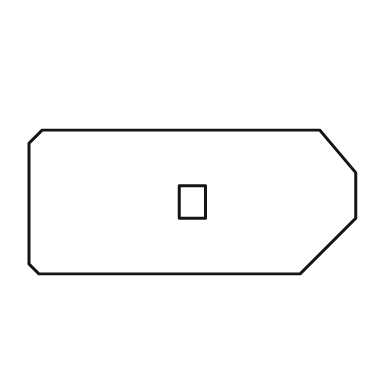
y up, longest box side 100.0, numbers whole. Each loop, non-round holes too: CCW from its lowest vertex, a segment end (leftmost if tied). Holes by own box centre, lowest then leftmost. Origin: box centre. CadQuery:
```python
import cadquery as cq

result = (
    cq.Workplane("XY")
    .moveTo(-47.0, -22.0)
    .lineTo(33.0, -22.0)
    .lineTo(50.0, -5.0)
    .lineTo(50.0, 9.0)
    .lineTo(39.0, 22.0)
    .lineTo(-46.0, 22.0)
    .lineTo(-50.0, 18.0)
    .lineTo(-50.0, -19.0)
    .close()
    .moveTo(-4.0, -5.0)
    .lineTo(4.0, -5.0)
    .lineTo(4.0, 5.0)
    .lineTo(-4.0, 5.0)
    .close()
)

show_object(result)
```